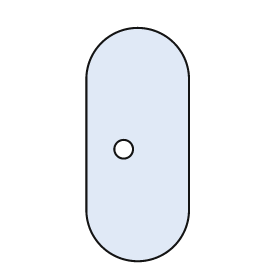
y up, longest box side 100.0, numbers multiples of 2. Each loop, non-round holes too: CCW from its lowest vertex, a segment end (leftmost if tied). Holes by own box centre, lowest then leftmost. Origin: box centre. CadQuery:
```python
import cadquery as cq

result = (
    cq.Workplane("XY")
    .moveTo(-22.0, -28.0)
    .threePointArc((0.0, -50.0), (22.0, -28.0))
    .lineTo(22.0, 28.0)
    .threePointArc((0.0, 50.0), (-22.0, 28.0))
    .close()
    .moveTo(-6.0, -2.0)
    .circle(4.0)
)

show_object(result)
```